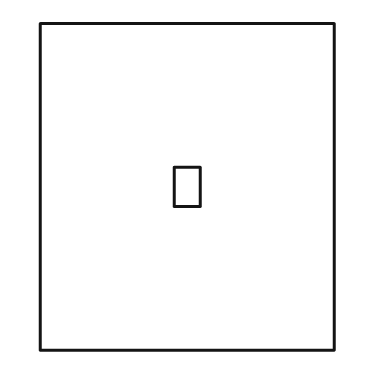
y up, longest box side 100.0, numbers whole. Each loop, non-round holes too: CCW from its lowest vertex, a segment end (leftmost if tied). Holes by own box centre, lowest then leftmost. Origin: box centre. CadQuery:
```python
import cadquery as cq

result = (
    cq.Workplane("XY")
    .moveTo(-45.0, -50.0)
    .lineTo(45.0, -50.0)
    .lineTo(45.0, 50.0)
    .lineTo(-45.0, 50.0)
    .close()
    .moveTo(-4.0, -6.0)
    .lineTo(4.0, -6.0)
    .lineTo(4.0, 6.0)
    .lineTo(-4.0, 6.0)
    .close()
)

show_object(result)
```